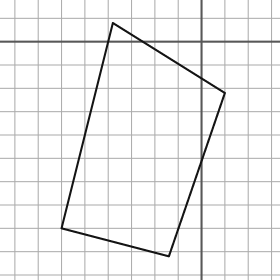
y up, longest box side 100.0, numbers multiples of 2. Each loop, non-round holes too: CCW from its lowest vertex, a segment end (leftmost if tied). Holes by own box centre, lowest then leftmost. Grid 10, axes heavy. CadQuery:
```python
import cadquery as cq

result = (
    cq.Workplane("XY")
    .moveTo(-14.0, -92.0)
    .lineTo(10.0, -22.0)
    .lineTo(-38.0, 8.0)
    .lineTo(-60.0, -80.0)
    .close()
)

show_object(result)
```